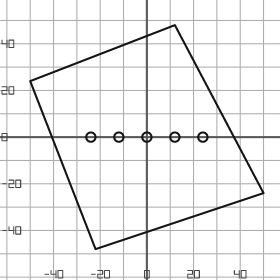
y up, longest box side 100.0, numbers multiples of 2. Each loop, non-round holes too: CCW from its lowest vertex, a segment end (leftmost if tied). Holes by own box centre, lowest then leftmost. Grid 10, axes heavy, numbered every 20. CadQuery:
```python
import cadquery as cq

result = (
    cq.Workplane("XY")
    .moveTo(-22.0, -48.0)
    .lineTo(50.0, -24.0)
    .lineTo(12.0, 48.0)
    .lineTo(-50.0, 24.0)
    .close()
    .moveTo(-24.0, 0.0)
    .circle(2.0)
    .moveTo(-12.0, 0.0)
    .circle(2.0)
    .moveTo(0.0, 0.0)
    .circle(2.0)
    .moveTo(12.0, 0.0)
    .circle(2.0)
    .moveTo(24.0, 0.0)
    .circle(2.0)
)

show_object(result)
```